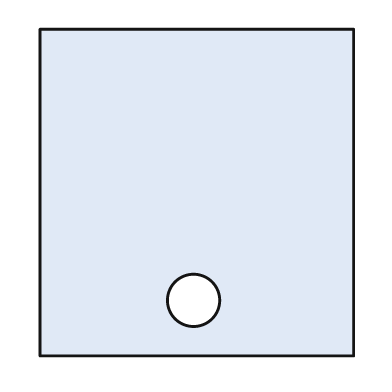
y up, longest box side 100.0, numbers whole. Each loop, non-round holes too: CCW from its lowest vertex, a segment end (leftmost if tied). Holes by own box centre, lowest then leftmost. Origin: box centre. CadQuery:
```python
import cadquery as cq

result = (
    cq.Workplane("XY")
    .moveTo(-48.0, -50.0)
    .lineTo(48.0, -50.0)
    .lineTo(48.0, 50.0)
    .lineTo(-48.0, 50.0)
    .close()
    .moveTo(-1.0, -33.0)
    .circle(8.0)
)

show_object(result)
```